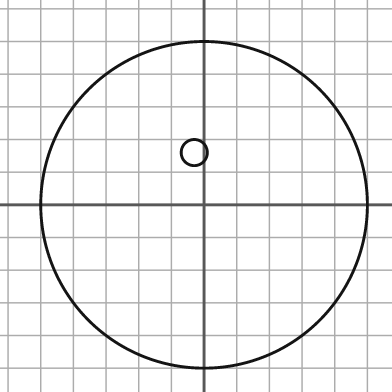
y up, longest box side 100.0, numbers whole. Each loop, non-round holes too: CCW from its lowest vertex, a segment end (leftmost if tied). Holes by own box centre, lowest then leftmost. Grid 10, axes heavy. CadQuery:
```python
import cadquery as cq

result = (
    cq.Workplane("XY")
    .moveTo(0.0, 0.0)
    .circle(50.0)
    .moveTo(-3.0, 16.0)
    .circle(4.0)
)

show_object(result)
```